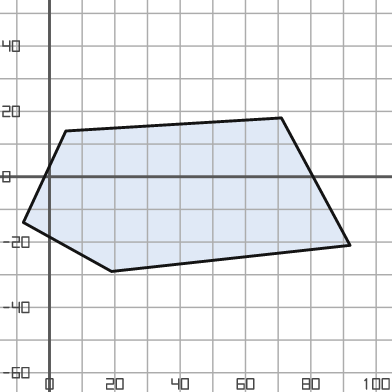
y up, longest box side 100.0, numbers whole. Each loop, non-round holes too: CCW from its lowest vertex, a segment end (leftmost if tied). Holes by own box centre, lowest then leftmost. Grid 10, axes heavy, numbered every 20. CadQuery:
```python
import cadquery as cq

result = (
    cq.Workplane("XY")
    .moveTo(19.0, -29.0)
    .lineTo(92.0, -21.0)
    .lineTo(71.0, 18.0)
    .lineTo(5.0, 14.0)
    .lineTo(-8.0, -14.0)
    .close()
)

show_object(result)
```